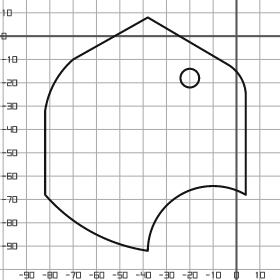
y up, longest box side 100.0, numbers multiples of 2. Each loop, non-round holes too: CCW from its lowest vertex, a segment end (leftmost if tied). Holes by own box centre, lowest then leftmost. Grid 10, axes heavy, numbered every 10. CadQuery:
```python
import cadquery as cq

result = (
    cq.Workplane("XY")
    .moveTo(-38.0, -92.0)
    .threePointArc((-24.0, -68.0), (4.0, -68.0))
    .lineTo(4.0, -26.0)
    .threePointArc((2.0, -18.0), (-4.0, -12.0))
    .lineTo(-38.0, 8.0)
    .lineTo(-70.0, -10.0)
    .threePointArc((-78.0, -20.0), (-82.0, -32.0))
    .lineTo(-82.0, -68.0)
    .threePointArc((-62.0, -84.0), (-38.0, -92.0))
    .close()
    .moveTo(-20.0, -18.0)
    .circle(4.0)
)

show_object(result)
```